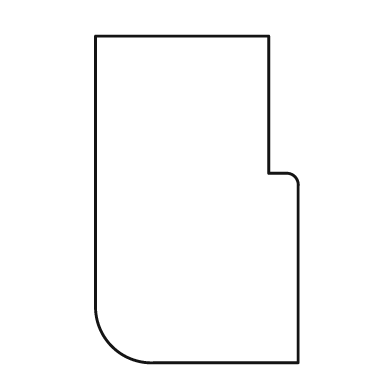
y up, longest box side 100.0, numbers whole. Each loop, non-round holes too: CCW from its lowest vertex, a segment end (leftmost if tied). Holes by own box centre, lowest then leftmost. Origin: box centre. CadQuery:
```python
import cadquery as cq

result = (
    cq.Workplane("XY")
    .moveTo(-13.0, -50.0)
    .lineTo(31.0, -50.0)
    .lineTo(31.0, 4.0)
    .threePointArc((30.0, 7.0), (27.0, 8.0))
    .lineTo(22.0, 8.0)
    .lineTo(22.0, 50.0)
    .lineTo(-31.0, 50.0)
    .lineTo(-31.0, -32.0)
    .threePointArc((-26.0, -45.0), (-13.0, -50.0))
    .close()
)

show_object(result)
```